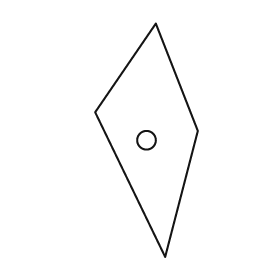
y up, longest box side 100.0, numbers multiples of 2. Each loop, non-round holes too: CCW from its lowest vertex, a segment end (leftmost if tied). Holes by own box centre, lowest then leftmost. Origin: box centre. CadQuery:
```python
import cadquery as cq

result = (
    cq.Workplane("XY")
    .moveTo(8.0, -50.0)
    .lineTo(22.0, 4.0)
    .lineTo(4.0, 50.0)
    .lineTo(-22.0, 12.0)
    .close()
    .moveTo(0.0, 0.0)
    .circle(4.0)
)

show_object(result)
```